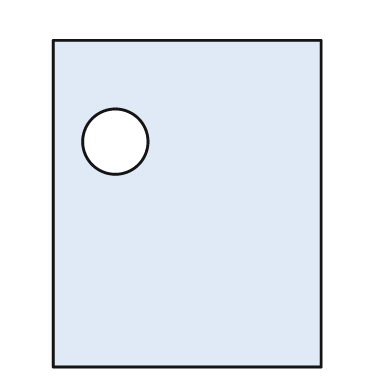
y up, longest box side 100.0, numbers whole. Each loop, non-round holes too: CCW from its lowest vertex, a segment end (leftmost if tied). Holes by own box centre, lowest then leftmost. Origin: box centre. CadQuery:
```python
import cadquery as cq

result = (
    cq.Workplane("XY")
    .moveTo(-41.0, -50.0)
    .lineTo(41.0, -50.0)
    .lineTo(41.0, 50.0)
    .lineTo(-41.0, 50.0)
    .close()
    .moveTo(-22.0, 19.0)
    .circle(10.0)
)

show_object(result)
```